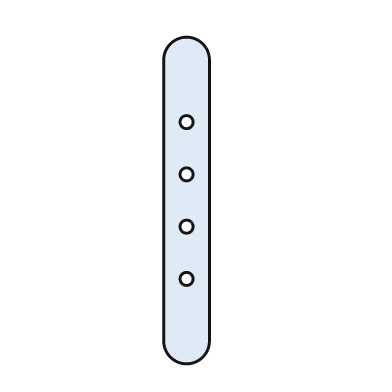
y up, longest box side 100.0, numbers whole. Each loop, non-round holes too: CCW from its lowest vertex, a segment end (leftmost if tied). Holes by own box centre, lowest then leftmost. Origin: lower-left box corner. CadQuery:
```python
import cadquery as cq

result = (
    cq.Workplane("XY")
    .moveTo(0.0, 7.0)
    .threePointArc((7.0, 0.0), (14.0, 7.0))
    .lineTo(14.0, 93.0)
    .threePointArc((7.0, 100.0), (0.0, 93.0))
    .close()
    .moveTo(7.0, 26.0)
    .circle(2.0)
    .moveTo(7.0, 42.0)
    .circle(2.0)
    .moveTo(7.0, 58.0)
    .circle(2.0)
    .moveTo(7.0, 74.0)
    .circle(2.0)
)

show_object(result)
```